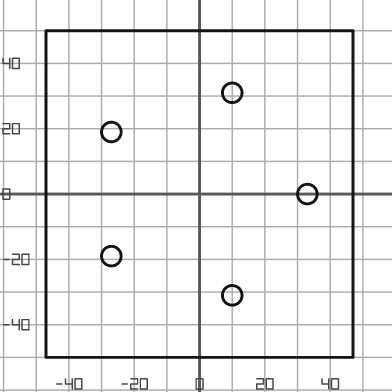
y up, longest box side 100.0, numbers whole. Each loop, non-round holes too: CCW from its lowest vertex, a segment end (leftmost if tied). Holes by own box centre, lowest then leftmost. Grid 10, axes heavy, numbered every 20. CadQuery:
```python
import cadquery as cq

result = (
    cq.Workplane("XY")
    .moveTo(-47.0, -50.0)
    .lineTo(47.0, -50.0)
    .lineTo(47.0, 50.0)
    .lineTo(-47.0, 50.0)
    .close()
    .moveTo(10.0, -31.0)
    .circle(3.0)
    .moveTo(-27.0, -19.0)
    .circle(3.0)
    .moveTo(33.0, 0.0)
    .circle(3.0)
    .moveTo(-27.0, 19.0)
    .circle(3.0)
    .moveTo(10.0, 31.0)
    .circle(3.0)
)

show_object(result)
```